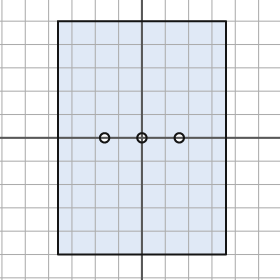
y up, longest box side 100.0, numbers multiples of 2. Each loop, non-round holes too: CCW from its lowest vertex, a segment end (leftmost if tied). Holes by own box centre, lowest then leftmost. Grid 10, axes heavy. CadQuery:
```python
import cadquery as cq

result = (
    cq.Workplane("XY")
    .moveTo(-36.0, -50.0)
    .lineTo(36.0, -50.0)
    .lineTo(36.0, 50.0)
    .lineTo(-36.0, 50.0)
    .close()
    .moveTo(-16.0, 0.0)
    .circle(2.0)
    .moveTo(0.0, 0.0)
    .circle(2.0)
    .moveTo(16.0, 0.0)
    .circle(2.0)
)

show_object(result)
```